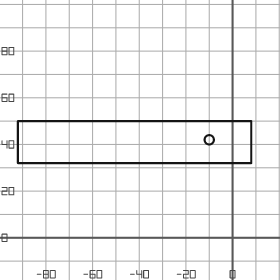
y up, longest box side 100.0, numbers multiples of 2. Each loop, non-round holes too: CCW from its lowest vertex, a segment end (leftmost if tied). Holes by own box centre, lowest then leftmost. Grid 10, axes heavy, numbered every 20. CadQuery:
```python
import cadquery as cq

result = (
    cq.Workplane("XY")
    .moveTo(-92.0, 32.0)
    .lineTo(8.0, 32.0)
    .lineTo(8.0, 50.0)
    .lineTo(-92.0, 50.0)
    .close()
    .moveTo(-10.0, 42.0)
    .circle(2.0)
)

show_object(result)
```